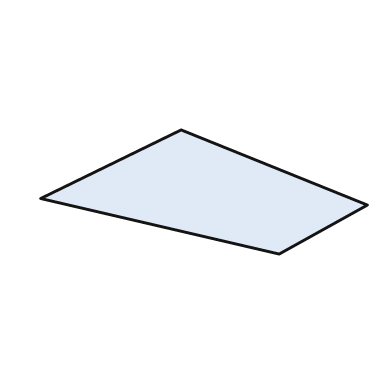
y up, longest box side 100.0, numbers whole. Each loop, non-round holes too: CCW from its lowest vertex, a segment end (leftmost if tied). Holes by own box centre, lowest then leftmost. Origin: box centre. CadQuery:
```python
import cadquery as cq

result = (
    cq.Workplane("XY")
    .moveTo(23.0, -19.0)
    .lineTo(50.0, -4.0)
    .lineTo(-7.0, 19.0)
    .lineTo(-50.0, -2.0)
    .close()
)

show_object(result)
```